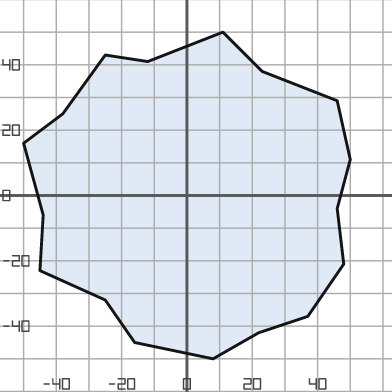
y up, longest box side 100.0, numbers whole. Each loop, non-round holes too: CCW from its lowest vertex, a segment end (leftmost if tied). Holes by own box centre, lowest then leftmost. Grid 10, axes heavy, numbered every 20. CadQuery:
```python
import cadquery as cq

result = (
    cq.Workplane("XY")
    .moveTo(8.0, -50.0)
    .lineTo(22.0, -42.0)
    .lineTo(37.0, -37.0)
    .lineTo(48.0, -21.0)
    .lineTo(46.0, -4.0)
    .lineTo(50.0, 11.0)
    .lineTo(46.0, 29.0)
    .lineTo(23.0, 38.0)
    .lineTo(11.0, 50.0)
    .lineTo(-12.0, 41.0)
    .lineTo(-25.0, 43.0)
    .lineTo(-38.0, 25.0)
    .lineTo(-50.0, 16.0)
    .lineTo(-44.0, -6.0)
    .lineTo(-45.0, -23.0)
    .lineTo(-25.0, -32.0)
    .lineTo(-16.0, -45.0)
    .close()
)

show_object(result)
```